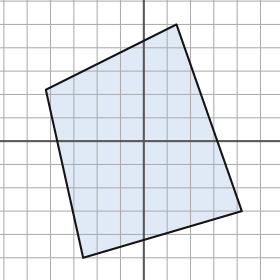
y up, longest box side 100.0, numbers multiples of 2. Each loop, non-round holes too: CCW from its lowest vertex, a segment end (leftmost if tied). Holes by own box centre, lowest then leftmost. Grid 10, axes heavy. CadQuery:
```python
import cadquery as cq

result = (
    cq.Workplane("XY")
    .moveTo(-26.0, -50.0)
    .lineTo(42.0, -30.0)
    .lineTo(14.0, 50.0)
    .lineTo(-42.0, 22.0)
    .close()
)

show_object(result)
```